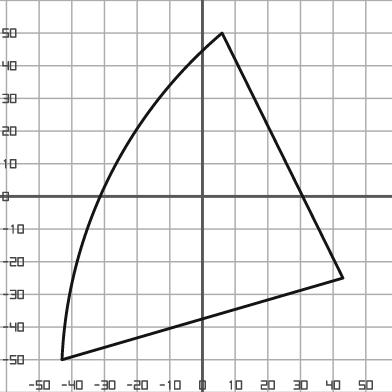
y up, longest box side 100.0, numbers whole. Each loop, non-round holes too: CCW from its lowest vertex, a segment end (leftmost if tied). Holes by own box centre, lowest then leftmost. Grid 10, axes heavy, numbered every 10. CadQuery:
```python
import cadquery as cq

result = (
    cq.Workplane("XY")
    .moveTo(-43.0, -50.0)
    .lineTo(43.0, -25.0)
    .lineTo(6.0, 50.0)
    .threePointArc((-29.0, 5.0), (-43.0, -50.0))
    .close()
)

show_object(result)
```